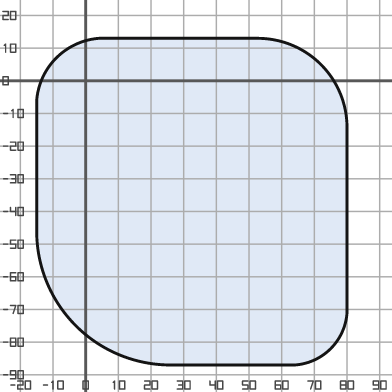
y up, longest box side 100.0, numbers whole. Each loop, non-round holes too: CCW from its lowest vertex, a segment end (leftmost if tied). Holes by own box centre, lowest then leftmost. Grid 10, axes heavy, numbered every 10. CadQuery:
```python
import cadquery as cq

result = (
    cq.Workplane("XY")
    .moveTo(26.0, -87.0)
    .lineTo(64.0, -87.0)
    .threePointArc((75.0, -82.0), (80.0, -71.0))
    .lineTo(80.0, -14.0)
    .threePointArc((72.0, 5.0), (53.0, 13.0))
    .lineTo(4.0, 13.0)
    .threePointArc((-9.0, 7.0), (-15.0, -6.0))
    .lineTo(-15.0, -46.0)
    .threePointArc((-3.0, -75.0), (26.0, -87.0))
    .close()
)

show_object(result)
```